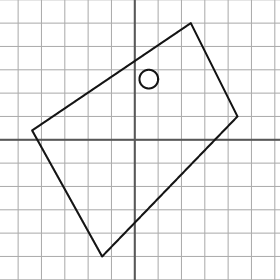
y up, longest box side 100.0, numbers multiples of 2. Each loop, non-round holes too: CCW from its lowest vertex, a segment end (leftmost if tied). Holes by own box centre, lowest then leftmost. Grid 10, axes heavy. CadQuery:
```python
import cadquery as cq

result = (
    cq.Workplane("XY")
    .moveTo(-14.0, -50.0)
    .lineTo(44.0, 10.0)
    .lineTo(24.0, 50.0)
    .lineTo(-44.0, 4.0)
    .close()
    .moveTo(6.0, 26.0)
    .circle(4.0)
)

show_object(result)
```